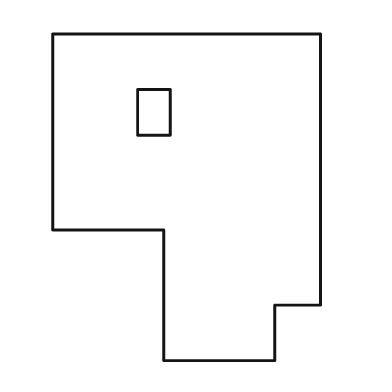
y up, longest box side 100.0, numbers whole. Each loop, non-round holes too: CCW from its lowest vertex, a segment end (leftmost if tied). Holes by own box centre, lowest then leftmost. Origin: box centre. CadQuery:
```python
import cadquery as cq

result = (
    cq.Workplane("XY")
    .moveTo(-7.0, -50.0)
    .lineTo(27.0, -50.0)
    .lineTo(27.0, -33.0)
    .lineTo(41.0, -33.0)
    .lineTo(41.0, 50.0)
    .lineTo(-41.0, 50.0)
    .lineTo(-41.0, -10.0)
    .lineTo(-7.0, -10.0)
    .close()
    .moveTo(-15.0, 19.0)
    .lineTo(-5.0, 19.0)
    .lineTo(-5.0, 33.0)
    .lineTo(-15.0, 33.0)
    .close()
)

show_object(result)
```